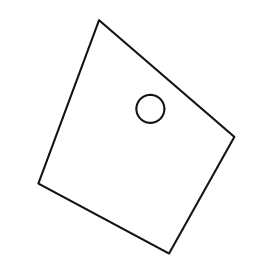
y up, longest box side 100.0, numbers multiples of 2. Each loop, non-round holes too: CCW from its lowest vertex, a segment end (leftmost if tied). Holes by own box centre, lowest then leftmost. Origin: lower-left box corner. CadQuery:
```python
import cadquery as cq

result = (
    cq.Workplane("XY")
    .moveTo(56.0, 0.0)
    .lineTo(84.0, 50.0)
    .lineTo(26.0, 100.0)
    .lineTo(0.0, 30.0)
    .close()
    .moveTo(48.0, 62.0)
    .circle(6.0)
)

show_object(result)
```